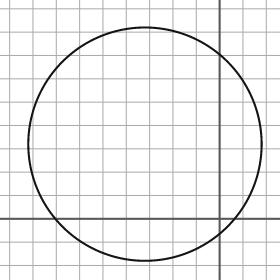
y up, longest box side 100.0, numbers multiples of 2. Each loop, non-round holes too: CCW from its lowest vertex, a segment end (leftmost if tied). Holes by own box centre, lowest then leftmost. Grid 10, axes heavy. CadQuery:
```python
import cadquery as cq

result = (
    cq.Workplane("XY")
    .moveTo(-32.0, 32.0)
    .circle(50.0)
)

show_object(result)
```